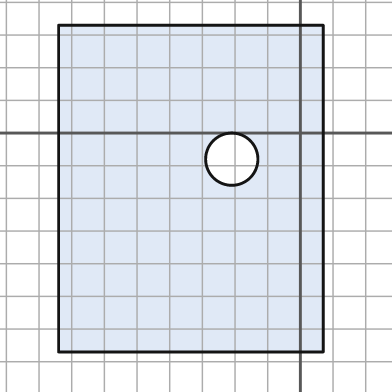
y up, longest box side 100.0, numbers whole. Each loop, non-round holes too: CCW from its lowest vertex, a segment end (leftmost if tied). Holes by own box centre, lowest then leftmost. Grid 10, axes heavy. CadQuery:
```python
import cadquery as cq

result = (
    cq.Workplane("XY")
    .moveTo(-74.0, -67.0)
    .lineTo(7.0, -67.0)
    .lineTo(7.0, 33.0)
    .lineTo(-74.0, 33.0)
    .close()
    .moveTo(-21.0, -8.0)
    .circle(8.0)
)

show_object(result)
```